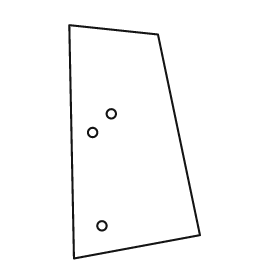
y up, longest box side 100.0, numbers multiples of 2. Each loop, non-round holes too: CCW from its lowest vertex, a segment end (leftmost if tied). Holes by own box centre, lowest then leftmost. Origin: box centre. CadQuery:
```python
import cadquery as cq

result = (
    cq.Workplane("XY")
    .moveTo(-26.0, -50.0)
    .lineTo(28.0, -40.0)
    .lineTo(10.0, 46.0)
    .lineTo(-28.0, 50.0)
    .close()
    .moveTo(-14.0, -36.0)
    .circle(2.0)
    .moveTo(-18.0, 4.0)
    .circle(2.0)
    .moveTo(-10.0, 12.0)
    .circle(2.0)
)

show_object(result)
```